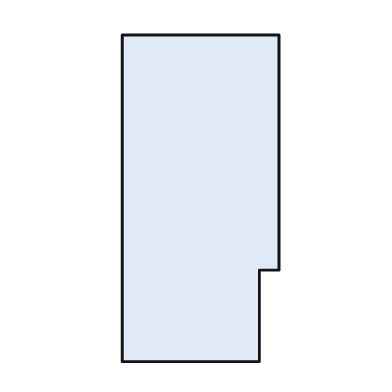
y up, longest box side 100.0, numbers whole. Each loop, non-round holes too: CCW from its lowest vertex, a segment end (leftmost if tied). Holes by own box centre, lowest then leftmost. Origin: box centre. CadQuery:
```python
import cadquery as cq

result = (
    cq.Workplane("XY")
    .moveTo(-24.0, -50.0)
    .lineTo(18.0, -50.0)
    .lineTo(18.0, -22.0)
    .lineTo(24.0, -22.0)
    .lineTo(24.0, 50.0)
    .lineTo(-24.0, 50.0)
    .close()
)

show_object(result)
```